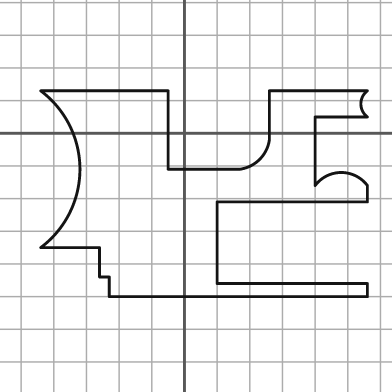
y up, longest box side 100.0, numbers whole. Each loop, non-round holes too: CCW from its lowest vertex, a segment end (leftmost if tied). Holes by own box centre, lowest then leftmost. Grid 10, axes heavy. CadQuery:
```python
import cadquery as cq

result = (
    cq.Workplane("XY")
    .moveTo(-23.0, -50.0)
    .lineTo(56.0, -50.0)
    .lineTo(56.0, -46.0)
    .lineTo(10.0, -46.0)
    .lineTo(10.0, -21.0)
    .lineTo(56.0, -21.0)
    .lineTo(56.0, -16.0)
    .threePointArc((48.0, -12.0), (40.0, -16.0))
    .lineTo(40.0, 5.0)
    .lineTo(56.0, 5.0)
    .threePointArc((54.0, 9.0), (56.0, 13.0))
    .lineTo(26.0, 13.0)
    .lineTo(26.0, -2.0)
    .threePointArc((23.0, -8.0), (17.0, -11.0))
    .lineTo(-5.0, -11.0)
    .lineTo(-5.0, 13.0)
    .lineTo(-44.0, 13.0)
    .threePointArc((-32.0, -11.0), (-44.0, -35.0))
    .lineTo(-26.0, -35.0)
    .lineTo(-26.0, -44.0)
    .lineTo(-23.0, -44.0)
    .close()
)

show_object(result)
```